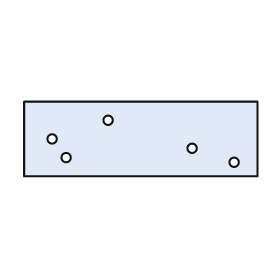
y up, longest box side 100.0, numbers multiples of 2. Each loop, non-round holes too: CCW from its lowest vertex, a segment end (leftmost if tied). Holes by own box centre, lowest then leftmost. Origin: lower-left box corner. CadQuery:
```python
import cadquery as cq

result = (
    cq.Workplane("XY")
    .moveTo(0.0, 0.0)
    .lineTo(100.0, 0.0)
    .lineTo(100.0, 32.0)
    .lineTo(0.0, 32.0)
    .close()
    .moveTo(90.0, 6.0)
    .circle(2.0)
    .moveTo(18.0, 8.0)
    .circle(2.0)
    .moveTo(72.0, 12.0)
    .circle(2.0)
    .moveTo(12.0, 16.0)
    .circle(2.0)
    .moveTo(36.0, 24.0)
    .circle(2.0)
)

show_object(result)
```